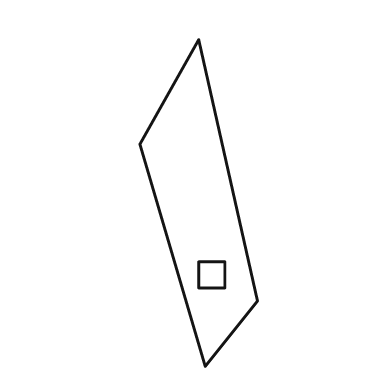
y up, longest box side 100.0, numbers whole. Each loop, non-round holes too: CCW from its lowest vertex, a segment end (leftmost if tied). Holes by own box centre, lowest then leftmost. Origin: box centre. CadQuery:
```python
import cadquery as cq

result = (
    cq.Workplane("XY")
    .moveTo(2.0, -50.0)
    .lineTo(18.0, -30.0)
    .lineTo(0.0, 50.0)
    .lineTo(-18.0, 18.0)
    .close()
    .moveTo(0.0, -26.0)
    .lineTo(8.0, -26.0)
    .lineTo(8.0, -18.0)
    .lineTo(0.0, -18.0)
    .close()
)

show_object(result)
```